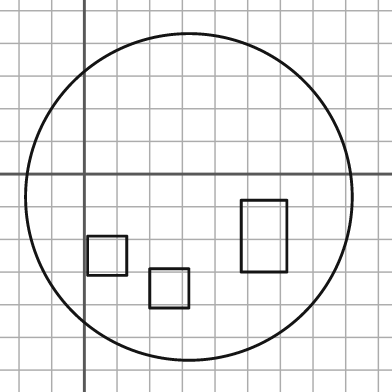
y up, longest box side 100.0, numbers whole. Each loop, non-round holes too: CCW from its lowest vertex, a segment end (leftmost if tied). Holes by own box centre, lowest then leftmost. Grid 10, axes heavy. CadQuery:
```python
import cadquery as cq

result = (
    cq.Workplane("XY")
    .moveTo(32.0, -7.0)
    .circle(50.0)
    .moveTo(20.0, -41.0)
    .lineTo(32.0, -41.0)
    .lineTo(32.0, -29.0)
    .lineTo(20.0, -29.0)
    .close()
    .moveTo(1.0, -31.0)
    .lineTo(13.0, -31.0)
    .lineTo(13.0, -19.0)
    .lineTo(1.0, -19.0)
    .close()
    .moveTo(48.0, -30.0)
    .lineTo(62.0, -30.0)
    .lineTo(62.0, -8.0)
    .lineTo(48.0, -8.0)
    .close()
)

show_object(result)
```